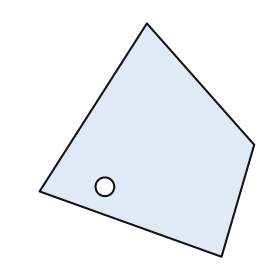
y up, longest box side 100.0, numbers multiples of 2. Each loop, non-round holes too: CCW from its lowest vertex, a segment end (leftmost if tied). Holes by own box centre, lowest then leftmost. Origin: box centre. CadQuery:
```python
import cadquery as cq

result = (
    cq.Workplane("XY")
    .moveTo(32.0, -50.0)
    .lineTo(46.0, -2.0)
    .lineTo(0.0, 50.0)
    .lineTo(-46.0, -22.0)
    .close()
    .moveTo(-18.0, -20.0)
    .circle(4.0)
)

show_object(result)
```